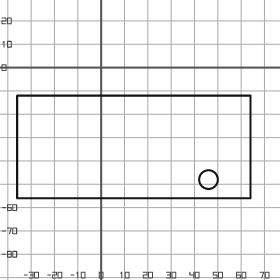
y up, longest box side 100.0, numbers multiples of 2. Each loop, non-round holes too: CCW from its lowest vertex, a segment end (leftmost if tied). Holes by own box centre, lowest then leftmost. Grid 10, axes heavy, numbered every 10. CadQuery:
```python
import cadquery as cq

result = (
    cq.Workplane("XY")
    .moveTo(-36.0, -56.0)
    .lineTo(64.0, -56.0)
    .lineTo(64.0, -12.0)
    .lineTo(-36.0, -12.0)
    .close()
    .moveTo(46.0, -48.0)
    .circle(4.0)
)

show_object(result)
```